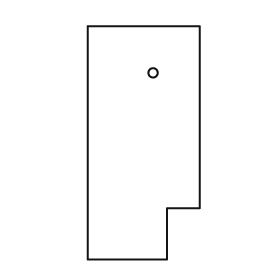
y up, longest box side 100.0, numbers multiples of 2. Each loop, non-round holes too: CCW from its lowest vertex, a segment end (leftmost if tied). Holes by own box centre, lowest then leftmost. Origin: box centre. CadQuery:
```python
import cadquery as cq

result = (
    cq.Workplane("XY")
    .moveTo(-24.0, -50.0)
    .lineTo(10.0, -50.0)
    .lineTo(10.0, -28.0)
    .lineTo(24.0, -28.0)
    .lineTo(24.0, 50.0)
    .lineTo(-24.0, 50.0)
    .close()
    .moveTo(4.0, 30.0)
    .circle(2.0)
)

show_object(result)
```